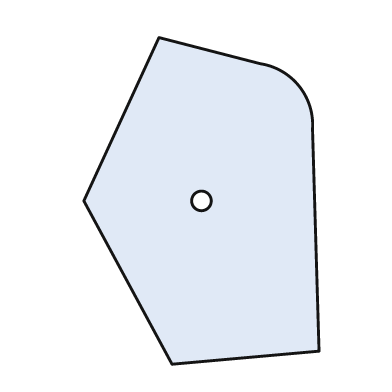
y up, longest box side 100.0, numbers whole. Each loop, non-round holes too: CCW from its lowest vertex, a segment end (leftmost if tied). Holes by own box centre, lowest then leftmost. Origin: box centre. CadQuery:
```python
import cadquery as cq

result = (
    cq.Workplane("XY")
    .moveTo(-9.0, -50.0)
    .lineTo(36.0, -46.0)
    .lineTo(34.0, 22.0)
    .threePointArc((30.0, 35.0), (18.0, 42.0))
    .lineTo(-13.0, 50.0)
    .lineTo(-36.0, 0.0)
    .close()
    .moveTo(0.0, 0.0)
    .circle(3.0)
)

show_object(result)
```